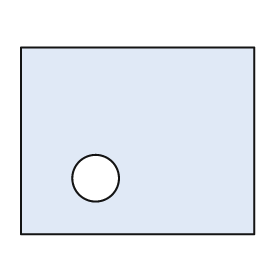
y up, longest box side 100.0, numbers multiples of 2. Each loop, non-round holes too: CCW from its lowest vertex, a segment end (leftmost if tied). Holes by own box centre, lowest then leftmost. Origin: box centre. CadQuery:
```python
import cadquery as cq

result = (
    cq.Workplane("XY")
    .moveTo(-50.0, -40.0)
    .lineTo(50.0, -40.0)
    .lineTo(50.0, 40.0)
    .lineTo(-50.0, 40.0)
    .close()
    .moveTo(-18.0, -16.0)
    .circle(10.0)
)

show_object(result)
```